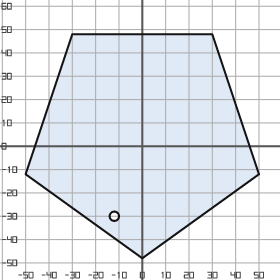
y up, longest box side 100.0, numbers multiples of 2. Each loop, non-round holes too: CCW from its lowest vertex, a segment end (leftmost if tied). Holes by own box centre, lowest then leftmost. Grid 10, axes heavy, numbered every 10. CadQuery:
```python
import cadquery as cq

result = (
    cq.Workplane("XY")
    .moveTo(0.0, -48.0)
    .lineTo(50.0, -12.0)
    .lineTo(30.0, 48.0)
    .lineTo(-30.0, 48.0)
    .lineTo(-50.0, -12.0)
    .close()
    .moveTo(-12.0, -30.0)
    .circle(2.0)
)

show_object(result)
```